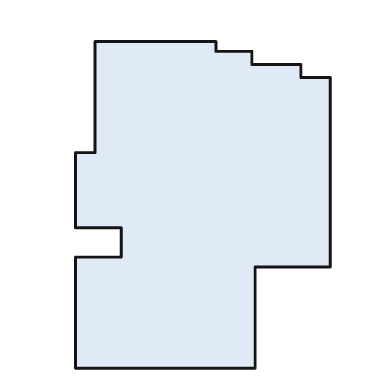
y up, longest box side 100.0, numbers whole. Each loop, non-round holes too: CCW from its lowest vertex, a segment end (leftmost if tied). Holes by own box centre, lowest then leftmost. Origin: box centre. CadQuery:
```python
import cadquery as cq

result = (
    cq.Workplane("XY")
    .moveTo(-39.0, -50.0)
    .lineTo(16.0, -50.0)
    .lineTo(16.0, -19.0)
    .lineTo(39.0, -19.0)
    .lineTo(39.0, 39.0)
    .lineTo(30.0, 39.0)
    .lineTo(30.0, 43.0)
    .lineTo(15.0, 43.0)
    .lineTo(15.0, 47.0)
    .lineTo(4.0, 47.0)
    .lineTo(4.0, 50.0)
    .lineTo(-33.0, 50.0)
    .lineTo(-33.0, 16.0)
    .lineTo(-39.0, 16.0)
    .lineTo(-39.0, -7.0)
    .lineTo(-25.0, -7.0)
    .lineTo(-25.0, -16.0)
    .lineTo(-39.0, -16.0)
    .close()
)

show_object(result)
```